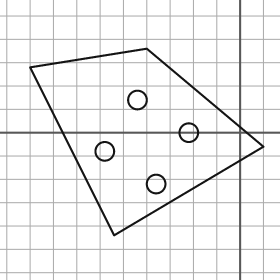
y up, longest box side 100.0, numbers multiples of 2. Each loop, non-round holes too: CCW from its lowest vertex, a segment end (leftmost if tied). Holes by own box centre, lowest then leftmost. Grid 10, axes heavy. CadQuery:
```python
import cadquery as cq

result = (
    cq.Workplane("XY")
    .moveTo(-54.0, -44.0)
    .lineTo(10.0, -6.0)
    .lineTo(-40.0, 36.0)
    .lineTo(-90.0, 28.0)
    .close()
    .moveTo(-36.0, -22.0)
    .circle(4.0)
    .moveTo(-58.0, -8.0)
    .circle(4.0)
    .moveTo(-22.0, 0.0)
    .circle(4.0)
    .moveTo(-44.0, 14.0)
    .circle(4.0)
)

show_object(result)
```